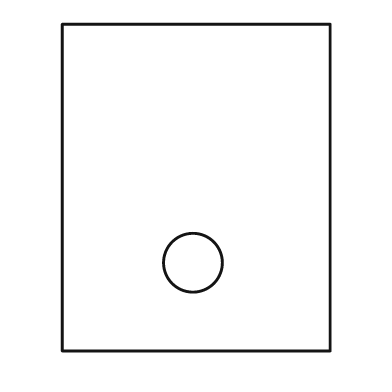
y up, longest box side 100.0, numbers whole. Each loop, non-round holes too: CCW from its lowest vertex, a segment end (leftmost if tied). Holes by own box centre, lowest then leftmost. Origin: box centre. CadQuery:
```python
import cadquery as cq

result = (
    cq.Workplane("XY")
    .moveTo(-41.0, -50.0)
    .lineTo(41.0, -50.0)
    .lineTo(41.0, 50.0)
    .lineTo(-41.0, 50.0)
    .close()
    .moveTo(-1.0, -23.0)
    .circle(9.0)
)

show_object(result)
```